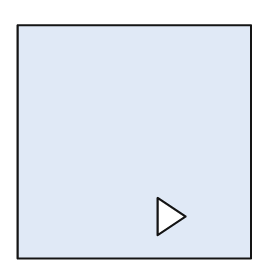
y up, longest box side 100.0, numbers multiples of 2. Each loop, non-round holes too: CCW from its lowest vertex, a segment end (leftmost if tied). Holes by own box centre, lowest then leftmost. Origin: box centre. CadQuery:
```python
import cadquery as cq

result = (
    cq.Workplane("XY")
    .moveTo(-50.0, -50.0)
    .lineTo(50.0, -50.0)
    .lineTo(50.0, 50.0)
    .lineTo(-50.0, 50.0)
    .close()
    .moveTo(10.0, -40.0)
    .lineTo(22.0, -32.0)
    .lineTo(10.0, -24.0)
    .close()
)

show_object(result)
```